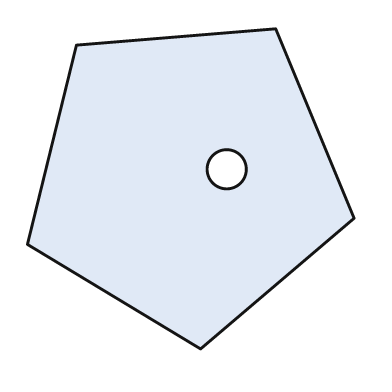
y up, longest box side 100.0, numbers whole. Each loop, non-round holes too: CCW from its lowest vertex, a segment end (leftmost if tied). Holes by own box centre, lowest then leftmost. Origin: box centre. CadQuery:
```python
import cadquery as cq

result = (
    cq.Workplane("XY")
    .moveTo(3.0, -49.0)
    .lineTo(50.0, -9.0)
    .lineTo(26.0, 49.0)
    .lineTo(-35.0, 44.0)
    .lineTo(-50.0, -17.0)
    .close()
    .moveTo(11.0, 6.0)
    .circle(6.0)
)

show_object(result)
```